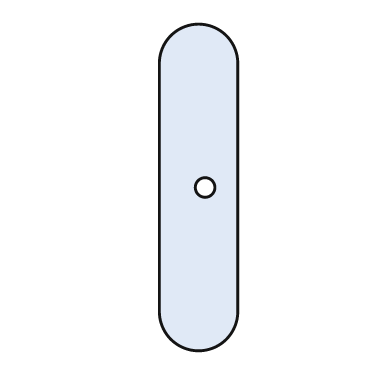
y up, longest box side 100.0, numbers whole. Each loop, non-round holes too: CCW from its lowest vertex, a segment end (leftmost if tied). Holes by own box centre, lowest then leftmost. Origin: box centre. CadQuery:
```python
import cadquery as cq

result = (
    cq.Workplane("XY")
    .moveTo(-12.0, -38.0)
    .threePointArc((0.0, -50.0), (12.0, -38.0))
    .lineTo(12.0, 38.0)
    .threePointArc((0.0, 50.0), (-12.0, 38.0))
    .close()
    .moveTo(2.0, 0.0)
    .circle(3.0)
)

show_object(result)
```